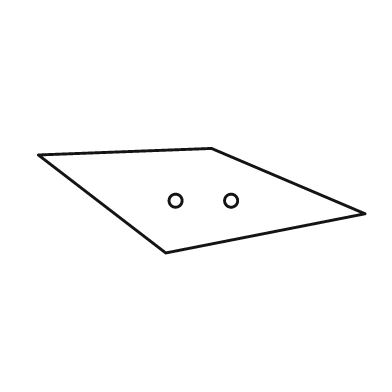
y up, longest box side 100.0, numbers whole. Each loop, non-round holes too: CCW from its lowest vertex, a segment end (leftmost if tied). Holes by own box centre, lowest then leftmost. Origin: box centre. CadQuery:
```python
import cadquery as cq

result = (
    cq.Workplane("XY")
    .moveTo(-11.0, -16.0)
    .lineTo(50.0, -4.0)
    .lineTo(3.0, 16.0)
    .lineTo(-50.0, 14.0)
    .close()
    .moveTo(-8.0, 0.0)
    .circle(2.0)
    .moveTo(9.0, 0.0)
    .circle(2.0)
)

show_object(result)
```